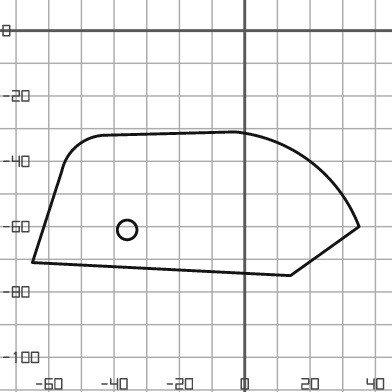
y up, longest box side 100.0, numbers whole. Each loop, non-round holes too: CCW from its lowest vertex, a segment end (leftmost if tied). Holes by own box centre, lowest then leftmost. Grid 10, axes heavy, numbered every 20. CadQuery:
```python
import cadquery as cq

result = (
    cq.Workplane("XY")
    .moveTo(14.0, -75.0)
    .lineTo(35.0, -60.0)
    .threePointArc((20.0, -40.0), (-3.0, -31.0))
    .lineTo(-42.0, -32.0)
    .threePointArc((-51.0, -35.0), (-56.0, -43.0))
    .lineTo(-65.0, -71.0)
    .close()
    .moveTo(-36.0, -61.0)
    .circle(3.0)
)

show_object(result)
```